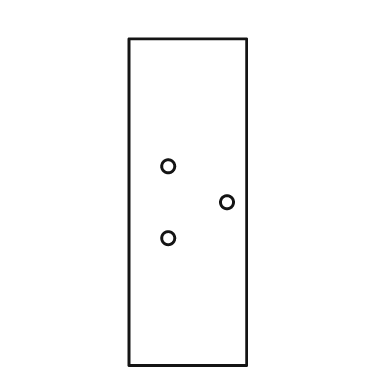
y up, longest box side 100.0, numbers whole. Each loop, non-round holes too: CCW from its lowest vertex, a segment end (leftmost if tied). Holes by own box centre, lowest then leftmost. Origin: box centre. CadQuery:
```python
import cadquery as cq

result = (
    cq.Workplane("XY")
    .moveTo(-18.0, -50.0)
    .lineTo(18.0, -50.0)
    .lineTo(18.0, 50.0)
    .lineTo(-18.0, 50.0)
    .close()
    .moveTo(-6.0, -11.0)
    .circle(2.0)
    .moveTo(12.0, 0.0)
    .circle(2.0)
    .moveTo(-6.0, 11.0)
    .circle(2.0)
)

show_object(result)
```